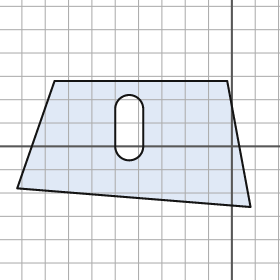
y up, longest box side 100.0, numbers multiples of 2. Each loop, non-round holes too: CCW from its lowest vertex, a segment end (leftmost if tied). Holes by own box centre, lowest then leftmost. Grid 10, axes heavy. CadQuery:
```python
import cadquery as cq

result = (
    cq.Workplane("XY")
    .moveTo(8.0, -26.0)
    .lineTo(-2.0, 28.0)
    .lineTo(-76.0, 28.0)
    .lineTo(-92.0, -18.0)
    .close()
    .moveTo(-50.0, 0.0)
    .threePointArc((-44.0, -6.0), (-38.0, 0.0))
    .lineTo(-38.0, 16.0)
    .threePointArc((-44.0, 22.0), (-50.0, 16.0))
    .close()
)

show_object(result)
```